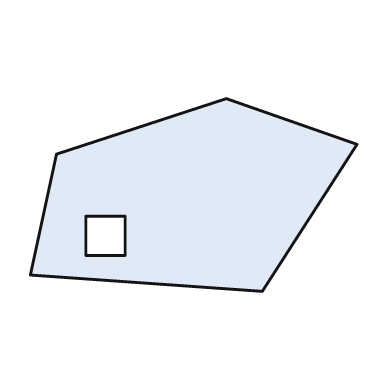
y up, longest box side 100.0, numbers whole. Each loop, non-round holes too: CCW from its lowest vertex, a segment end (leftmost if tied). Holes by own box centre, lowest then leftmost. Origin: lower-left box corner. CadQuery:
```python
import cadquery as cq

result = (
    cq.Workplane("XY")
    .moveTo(71.0, 0.0)
    .lineTo(100.0, 45.0)
    .lineTo(60.0, 59.0)
    .lineTo(8.0, 42.0)
    .lineTo(0.0, 5.0)
    .close()
    .moveTo(17.0, 11.0)
    .lineTo(29.0, 11.0)
    .lineTo(29.0, 23.0)
    .lineTo(17.0, 23.0)
    .close()
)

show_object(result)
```